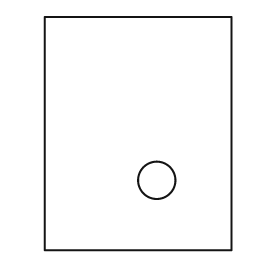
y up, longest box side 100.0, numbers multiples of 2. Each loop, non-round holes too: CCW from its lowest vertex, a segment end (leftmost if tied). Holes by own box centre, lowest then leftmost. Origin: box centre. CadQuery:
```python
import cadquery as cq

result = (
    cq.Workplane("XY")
    .moveTo(-40.0, -50.0)
    .lineTo(40.0, -50.0)
    .lineTo(40.0, 50.0)
    .lineTo(-40.0, 50.0)
    .close()
    .moveTo(8.0, -20.0)
    .circle(8.0)
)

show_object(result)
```